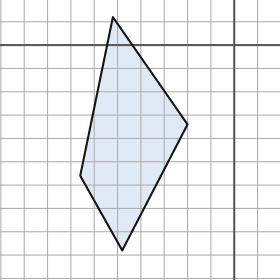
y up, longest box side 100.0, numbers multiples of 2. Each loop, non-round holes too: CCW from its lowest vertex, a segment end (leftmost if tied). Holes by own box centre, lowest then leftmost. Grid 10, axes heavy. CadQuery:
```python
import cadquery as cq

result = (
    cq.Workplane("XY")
    .moveTo(-48.0, -88.0)
    .lineTo(-20.0, -34.0)
    .lineTo(-52.0, 12.0)
    .lineTo(-66.0, -56.0)
    .close()
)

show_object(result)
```